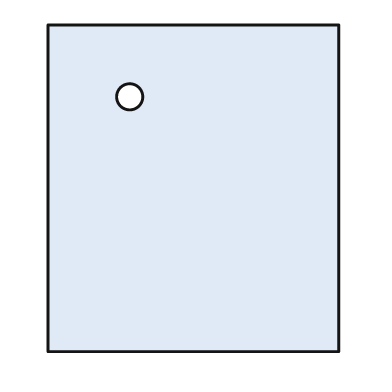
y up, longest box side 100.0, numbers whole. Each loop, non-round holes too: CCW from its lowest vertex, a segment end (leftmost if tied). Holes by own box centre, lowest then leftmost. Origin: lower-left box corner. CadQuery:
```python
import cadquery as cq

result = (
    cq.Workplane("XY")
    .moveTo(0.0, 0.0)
    .lineTo(89.0, 0.0)
    .lineTo(89.0, 100.0)
    .lineTo(0.0, 100.0)
    .close()
    .moveTo(25.0, 78.0)
    .circle(4.0)
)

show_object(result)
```